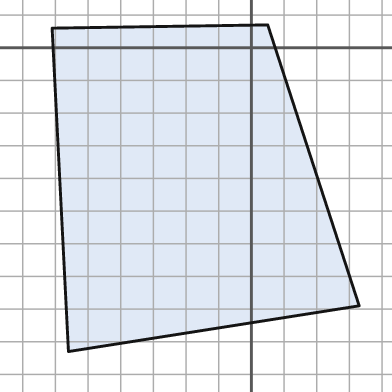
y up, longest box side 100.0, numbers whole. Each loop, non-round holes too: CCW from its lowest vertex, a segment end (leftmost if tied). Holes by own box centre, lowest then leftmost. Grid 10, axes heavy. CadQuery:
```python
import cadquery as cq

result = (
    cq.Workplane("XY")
    .moveTo(-56.0, -93.0)
    .lineTo(33.0, -79.0)
    .lineTo(5.0, 7.0)
    .lineTo(-61.0, 6.0)
    .close()
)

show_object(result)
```